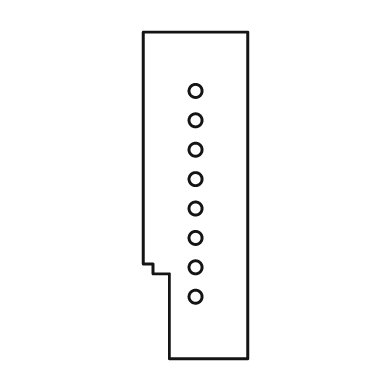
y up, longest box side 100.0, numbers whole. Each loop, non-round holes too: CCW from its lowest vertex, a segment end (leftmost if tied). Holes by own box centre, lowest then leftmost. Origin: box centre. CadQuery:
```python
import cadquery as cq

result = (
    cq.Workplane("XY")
    .moveTo(-8.0, -50.0)
    .lineTo(16.0, -50.0)
    .lineTo(16.0, 50.0)
    .lineTo(-16.0, 50.0)
    .lineTo(-16.0, -21.0)
    .lineTo(-13.0, -21.0)
    .lineTo(-13.0, -24.0)
    .lineTo(-8.0, -24.0)
    .close()
    .moveTo(0.0, -31.0)
    .circle(2.0)
    .moveTo(0.0, -22.0)
    .circle(2.0)
    .moveTo(0.0, -13.0)
    .circle(2.0)
    .moveTo(0.0, -4.0)
    .circle(2.0)
    .moveTo(0.0, 5.0)
    .circle(2.0)
    .moveTo(0.0, 14.0)
    .circle(2.0)
    .moveTo(0.0, 23.0)
    .circle(2.0)
    .moveTo(0.0, 32.0)
    .circle(2.0)
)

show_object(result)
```